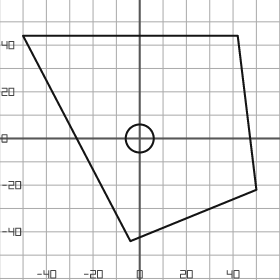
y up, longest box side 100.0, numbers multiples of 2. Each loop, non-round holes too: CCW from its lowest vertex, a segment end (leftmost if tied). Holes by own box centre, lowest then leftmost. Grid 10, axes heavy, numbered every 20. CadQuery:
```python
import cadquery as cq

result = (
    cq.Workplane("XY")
    .moveTo(-4.0, -44.0)
    .lineTo(50.0, -22.0)
    .lineTo(42.0, 44.0)
    .lineTo(-50.0, 44.0)
    .close()
    .moveTo(0.0, 0.0)
    .circle(6.0)
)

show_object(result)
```